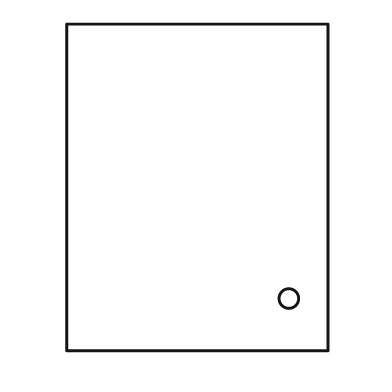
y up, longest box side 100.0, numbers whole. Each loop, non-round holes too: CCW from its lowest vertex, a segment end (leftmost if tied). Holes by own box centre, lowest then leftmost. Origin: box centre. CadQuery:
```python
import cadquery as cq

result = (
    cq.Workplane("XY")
    .moveTo(-40.0, -50.0)
    .lineTo(40.0, -50.0)
    .lineTo(40.0, 50.0)
    .lineTo(-40.0, 50.0)
    .close()
    .moveTo(28.0, -34.0)
    .circle(3.0)
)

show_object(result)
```